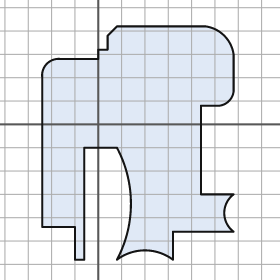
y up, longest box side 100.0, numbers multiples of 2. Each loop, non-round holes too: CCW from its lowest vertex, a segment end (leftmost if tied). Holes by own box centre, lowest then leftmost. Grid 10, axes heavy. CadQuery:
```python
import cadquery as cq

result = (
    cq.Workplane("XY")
    .moveTo(-10.0, -58.0)
    .lineTo(-6.0, -58.0)
    .lineTo(-6.0, -10.0)
    .lineTo(8.0, -10.0)
    .threePointArc((14.0, -34.0), (8.0, -58.0))
    .threePointArc((20.0, -54.0), (32.0, -58.0))
    .lineTo(32.0, -46.0)
    .lineTo(58.0, -46.0)
    .threePointArc((54.0, -38.0), (58.0, -30.0))
    .lineTo(44.0, -30.0)
    .lineTo(44.0, 8.0)
    .lineTo(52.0, 8.0)
    .threePointArc((56.0, 10.0), (58.0, 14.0))
    .lineTo(58.0, 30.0)
    .threePointArc((54.0, 38.0), (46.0, 42.0))
    .lineTo(8.0, 42.0)
    .lineTo(4.0, 38.0)
    .lineTo(4.0, 32.0)
    .lineTo(0.0, 32.0)
    .lineTo(0.0, 28.0)
    .lineTo(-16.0, 28.0)
    .threePointArc((-22.0, 26.0), (-24.0, 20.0))
    .lineTo(-24.0, -44.0)
    .lineTo(-10.0, -44.0)
    .close()
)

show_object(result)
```